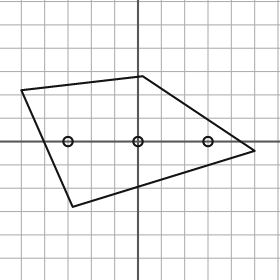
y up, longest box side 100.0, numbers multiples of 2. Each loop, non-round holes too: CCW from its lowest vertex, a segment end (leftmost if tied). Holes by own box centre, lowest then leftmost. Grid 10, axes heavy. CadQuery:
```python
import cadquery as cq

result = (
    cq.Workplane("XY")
    .moveTo(-28.0, -28.0)
    .lineTo(50.0, -4.0)
    .lineTo(2.0, 28.0)
    .lineTo(-50.0, 22.0)
    .close()
    .moveTo(-30.0, 0.0)
    .circle(2.0)
    .moveTo(0.0, 0.0)
    .circle(2.0)
    .moveTo(30.0, 0.0)
    .circle(2.0)
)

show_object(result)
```